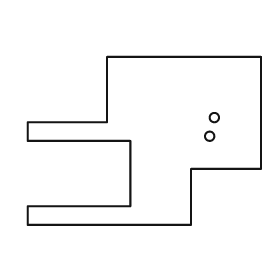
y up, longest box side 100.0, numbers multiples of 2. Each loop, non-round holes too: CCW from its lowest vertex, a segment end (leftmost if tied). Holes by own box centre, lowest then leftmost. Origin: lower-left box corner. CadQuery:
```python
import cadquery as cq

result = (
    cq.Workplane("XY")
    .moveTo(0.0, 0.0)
    .lineTo(70.0, 0.0)
    .lineTo(70.0, 24.0)
    .lineTo(100.0, 24.0)
    .lineTo(100.0, 72.0)
    .lineTo(34.0, 72.0)
    .lineTo(34.0, 44.0)
    .lineTo(0.0, 44.0)
    .lineTo(0.0, 36.0)
    .lineTo(44.0, 36.0)
    .lineTo(44.0, 8.0)
    .lineTo(0.0, 8.0)
    .close()
    .moveTo(78.0, 38.0)
    .circle(2.0)
    .moveTo(80.0, 46.0)
    .circle(2.0)
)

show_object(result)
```